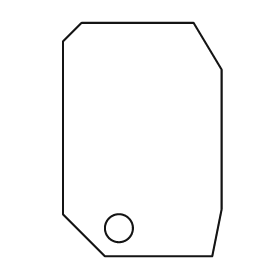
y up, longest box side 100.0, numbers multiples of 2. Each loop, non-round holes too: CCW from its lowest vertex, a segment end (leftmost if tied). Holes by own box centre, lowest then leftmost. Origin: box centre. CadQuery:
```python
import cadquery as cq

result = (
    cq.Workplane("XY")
    .moveTo(-16.0, -50.0)
    .lineTo(30.0, -50.0)
    .lineTo(34.0, -30.0)
    .lineTo(34.0, 30.0)
    .lineTo(22.0, 50.0)
    .lineTo(-26.0, 50.0)
    .lineTo(-34.0, 42.0)
    .lineTo(-34.0, -32.0)
    .close()
    .moveTo(-10.0, -38.0)
    .circle(6.0)
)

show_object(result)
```